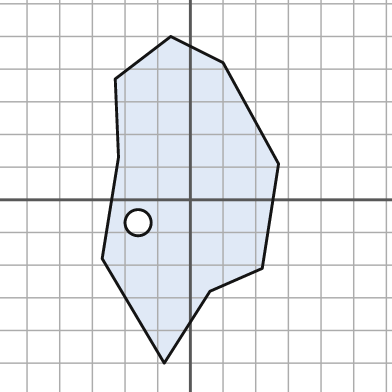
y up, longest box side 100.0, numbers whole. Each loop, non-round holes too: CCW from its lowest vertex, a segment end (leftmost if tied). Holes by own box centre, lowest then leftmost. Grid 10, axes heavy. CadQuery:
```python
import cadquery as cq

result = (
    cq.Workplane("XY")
    .moveTo(-8.0, -50.0)
    .lineTo(6.0, -28.0)
    .lineTo(22.0, -21.0)
    .lineTo(27.0, 11.0)
    .lineTo(10.0, 42.0)
    .lineTo(-6.0, 50.0)
    .lineTo(-23.0, 37.0)
    .lineTo(-22.0, 13.0)
    .lineTo(-27.0, -18.0)
    .close()
    .moveTo(-16.0, -7.0)
    .circle(4.0)
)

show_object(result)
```